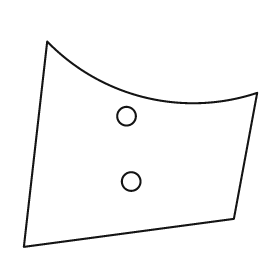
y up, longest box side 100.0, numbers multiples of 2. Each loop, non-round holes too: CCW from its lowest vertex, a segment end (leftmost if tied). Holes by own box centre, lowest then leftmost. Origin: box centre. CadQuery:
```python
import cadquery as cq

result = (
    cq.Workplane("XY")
    .moveTo(-50.0, -44.0)
    .lineTo(40.0, -32.0)
    .lineTo(50.0, 22.0)
    .threePointArc((2.0, 20.0), (-40.0, 44.0))
    .close()
    .moveTo(-4.0, -16.0)
    .circle(4.0)
    .moveTo(-6.0, 12.0)
    .circle(4.0)
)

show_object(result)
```